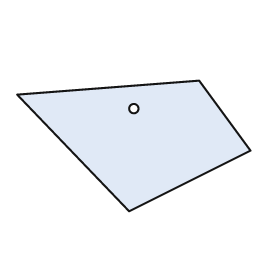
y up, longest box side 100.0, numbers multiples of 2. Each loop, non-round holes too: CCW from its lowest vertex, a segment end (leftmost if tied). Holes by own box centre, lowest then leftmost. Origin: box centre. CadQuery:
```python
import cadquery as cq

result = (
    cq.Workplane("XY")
    .moveTo(-2.0, -28.0)
    .lineTo(50.0, -2.0)
    .lineTo(28.0, 28.0)
    .lineTo(-50.0, 22.0)
    .close()
    .moveTo(0.0, 16.0)
    .circle(2.0)
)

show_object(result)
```